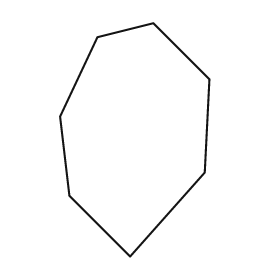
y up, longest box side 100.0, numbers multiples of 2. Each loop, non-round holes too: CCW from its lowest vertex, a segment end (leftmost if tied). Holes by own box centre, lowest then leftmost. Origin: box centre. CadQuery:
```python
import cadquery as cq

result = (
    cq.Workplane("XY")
    .moveTo(-2.0, -50.0)
    .lineTo(30.0, -14.0)
    .lineTo(32.0, 26.0)
    .lineTo(8.0, 50.0)
    .lineTo(-16.0, 44.0)
    .lineTo(-32.0, 10.0)
    .lineTo(-28.0, -24.0)
    .close()
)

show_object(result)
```